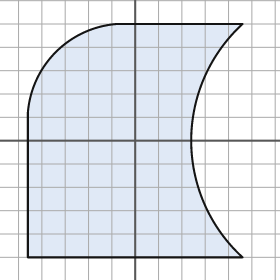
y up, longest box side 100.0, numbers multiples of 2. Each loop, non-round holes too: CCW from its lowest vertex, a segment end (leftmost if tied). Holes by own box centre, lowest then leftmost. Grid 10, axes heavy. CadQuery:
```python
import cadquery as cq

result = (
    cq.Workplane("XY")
    .moveTo(-46.0, -50.0)
    .lineTo(46.0, -50.0)
    .threePointArc((24.0, 0.0), (46.0, 50.0))
    .lineTo(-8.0, 50.0)
    .threePointArc((-34.0, 38.0), (-46.0, 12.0))
    .close()
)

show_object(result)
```